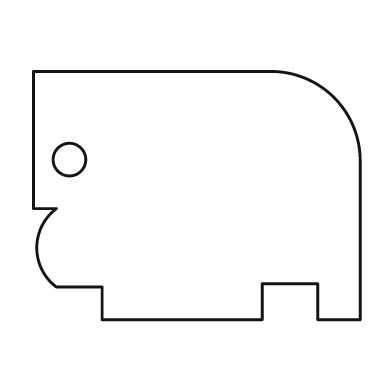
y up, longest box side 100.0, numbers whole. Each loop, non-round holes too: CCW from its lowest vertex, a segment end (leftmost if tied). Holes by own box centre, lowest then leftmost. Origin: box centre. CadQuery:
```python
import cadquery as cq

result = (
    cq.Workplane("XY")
    .moveTo(-29.0, -38.0)
    .lineTo(20.0, -38.0)
    .lineTo(20.0, -27.0)
    .lineTo(37.0, -27.0)
    .lineTo(37.0, -38.0)
    .lineTo(50.0, -38.0)
    .lineTo(50.0, 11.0)
    .threePointArc((42.0, 30.0), (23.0, 38.0))
    .lineTo(-50.0, 38.0)
    .lineTo(-50.0, -4.0)
    .lineTo(-43.0, -4.0)
    .threePointArc((-49.0, -16.0), (-43.0, -28.0))
    .lineTo(-29.0, -28.0)
    .close()
    .moveTo(-39.0, 11.0)
    .circle(5.0)
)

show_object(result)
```